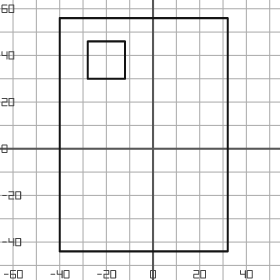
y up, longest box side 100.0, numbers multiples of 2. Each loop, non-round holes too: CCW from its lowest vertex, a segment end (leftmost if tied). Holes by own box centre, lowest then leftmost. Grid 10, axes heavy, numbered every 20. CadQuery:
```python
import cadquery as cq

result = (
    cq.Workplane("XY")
    .moveTo(-40.0, -44.0)
    .lineTo(32.0, -44.0)
    .lineTo(32.0, 56.0)
    .lineTo(-40.0, 56.0)
    .close()
    .moveTo(-28.0, 30.0)
    .lineTo(-12.0, 30.0)
    .lineTo(-12.0, 46.0)
    .lineTo(-28.0, 46.0)
    .close()
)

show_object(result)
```